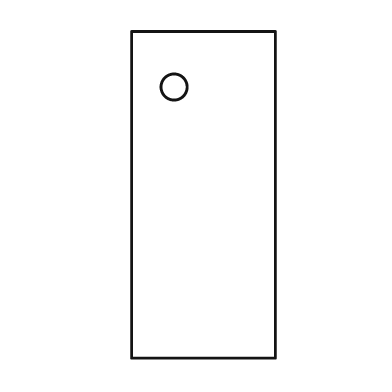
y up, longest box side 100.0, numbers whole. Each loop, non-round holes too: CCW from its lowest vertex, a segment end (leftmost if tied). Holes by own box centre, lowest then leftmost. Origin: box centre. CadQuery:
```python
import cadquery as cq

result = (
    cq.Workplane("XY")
    .moveTo(-22.0, -50.0)
    .lineTo(22.0, -50.0)
    .lineTo(22.0, 50.0)
    .lineTo(-22.0, 50.0)
    .close()
    .moveTo(-9.0, 33.0)
    .circle(4.0)
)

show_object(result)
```